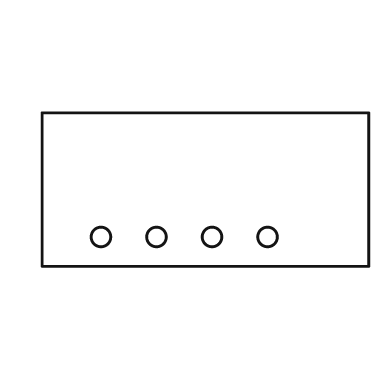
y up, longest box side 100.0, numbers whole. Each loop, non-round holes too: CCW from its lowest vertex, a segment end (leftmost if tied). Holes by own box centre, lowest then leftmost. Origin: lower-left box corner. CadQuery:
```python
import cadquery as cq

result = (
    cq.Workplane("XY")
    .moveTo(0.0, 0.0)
    .lineTo(100.0, 0.0)
    .lineTo(100.0, 47.0)
    .lineTo(0.0, 47.0)
    .close()
    .moveTo(18.0, 9.0)
    .circle(3.0)
    .moveTo(35.0, 9.0)
    .circle(3.0)
    .moveTo(52.0, 9.0)
    .circle(3.0)
    .moveTo(69.0, 9.0)
    .circle(3.0)
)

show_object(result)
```